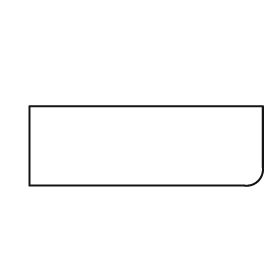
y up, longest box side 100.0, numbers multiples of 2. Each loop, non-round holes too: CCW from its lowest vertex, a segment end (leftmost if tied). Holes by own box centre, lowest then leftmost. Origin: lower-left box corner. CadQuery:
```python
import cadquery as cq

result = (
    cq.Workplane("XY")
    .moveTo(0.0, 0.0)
    .lineTo(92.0, 0.0)
    .threePointArc((98.0, 2.0), (100.0, 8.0))
    .lineTo(100.0, 34.0)
    .lineTo(0.0, 34.0)
    .close()
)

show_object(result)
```